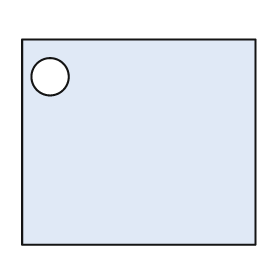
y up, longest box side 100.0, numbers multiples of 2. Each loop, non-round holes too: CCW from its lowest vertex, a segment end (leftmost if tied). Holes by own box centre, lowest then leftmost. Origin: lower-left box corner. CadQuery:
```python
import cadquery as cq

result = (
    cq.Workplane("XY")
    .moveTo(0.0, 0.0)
    .lineTo(100.0, 0.0)
    .lineTo(100.0, 88.0)
    .lineTo(0.0, 88.0)
    .close()
    .moveTo(12.0, 72.0)
    .circle(8.0)
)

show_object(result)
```